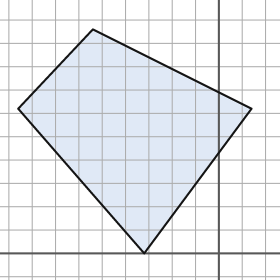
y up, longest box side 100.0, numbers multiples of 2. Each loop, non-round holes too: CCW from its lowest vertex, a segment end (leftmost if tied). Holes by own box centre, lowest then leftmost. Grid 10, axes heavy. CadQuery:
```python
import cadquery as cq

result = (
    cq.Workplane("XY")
    .moveTo(-32.0, 0.0)
    .lineTo(14.0, 62.0)
    .lineTo(-54.0, 96.0)
    .lineTo(-86.0, 62.0)
    .close()
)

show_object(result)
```